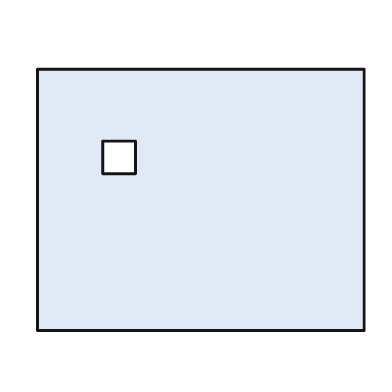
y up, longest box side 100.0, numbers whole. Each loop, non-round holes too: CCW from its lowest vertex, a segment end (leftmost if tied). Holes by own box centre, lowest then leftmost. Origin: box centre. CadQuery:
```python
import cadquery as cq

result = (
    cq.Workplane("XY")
    .moveTo(-50.0, -40.0)
    .lineTo(50.0, -40.0)
    .lineTo(50.0, 40.0)
    .lineTo(-50.0, 40.0)
    .close()
    .moveTo(-30.0, 8.0)
    .lineTo(-20.0, 8.0)
    .lineTo(-20.0, 18.0)
    .lineTo(-30.0, 18.0)
    .close()
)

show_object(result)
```